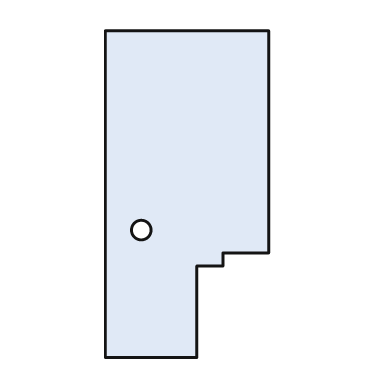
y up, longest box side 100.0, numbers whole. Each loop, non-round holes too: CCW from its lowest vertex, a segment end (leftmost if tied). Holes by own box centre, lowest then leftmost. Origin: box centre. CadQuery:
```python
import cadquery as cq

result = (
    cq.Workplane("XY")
    .moveTo(-25.0, -50.0)
    .lineTo(3.0, -50.0)
    .lineTo(3.0, -22.0)
    .lineTo(11.0, -22.0)
    .lineTo(11.0, -18.0)
    .lineTo(25.0, -18.0)
    .lineTo(25.0, 50.0)
    .lineTo(-25.0, 50.0)
    .close()
    .moveTo(-14.0, -11.0)
    .circle(3.0)
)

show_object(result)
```